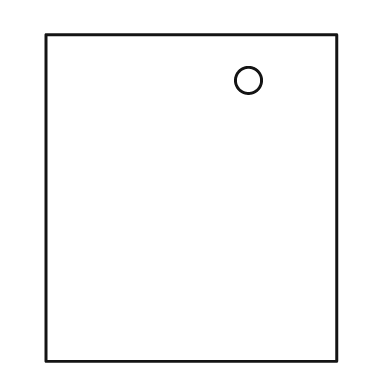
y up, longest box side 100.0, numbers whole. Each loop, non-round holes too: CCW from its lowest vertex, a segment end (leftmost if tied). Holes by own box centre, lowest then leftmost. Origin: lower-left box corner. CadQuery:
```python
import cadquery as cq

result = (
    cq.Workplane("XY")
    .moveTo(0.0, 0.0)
    .lineTo(89.0, 0.0)
    .lineTo(89.0, 100.0)
    .lineTo(0.0, 100.0)
    .close()
    .moveTo(62.0, 86.0)
    .circle(4.0)
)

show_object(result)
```